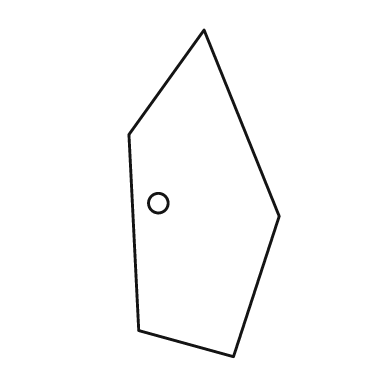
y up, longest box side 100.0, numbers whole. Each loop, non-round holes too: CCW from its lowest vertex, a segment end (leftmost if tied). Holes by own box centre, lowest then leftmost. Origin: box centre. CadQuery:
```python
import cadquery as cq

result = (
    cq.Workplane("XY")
    .moveTo(9.0, -50.0)
    .lineTo(23.0, -7.0)
    .lineTo(0.0, 50.0)
    .lineTo(-23.0, 18.0)
    .lineTo(-20.0, -42.0)
    .close()
    .moveTo(-14.0, -3.0)
    .circle(3.0)
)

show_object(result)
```